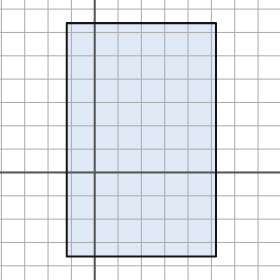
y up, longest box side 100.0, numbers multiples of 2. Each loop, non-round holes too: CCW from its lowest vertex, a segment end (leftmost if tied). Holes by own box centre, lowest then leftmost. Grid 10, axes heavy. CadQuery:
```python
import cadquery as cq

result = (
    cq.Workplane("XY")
    .moveTo(-12.0, -36.0)
    .lineTo(52.0, -36.0)
    .lineTo(52.0, 64.0)
    .lineTo(-12.0, 64.0)
    .close()
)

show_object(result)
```